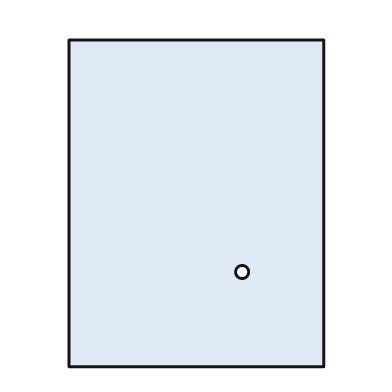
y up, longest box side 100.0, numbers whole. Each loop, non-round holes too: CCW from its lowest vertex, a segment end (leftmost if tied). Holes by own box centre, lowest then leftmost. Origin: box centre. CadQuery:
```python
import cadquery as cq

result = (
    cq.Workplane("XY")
    .moveTo(-39.0, -50.0)
    .lineTo(39.0, -50.0)
    .lineTo(39.0, 50.0)
    .lineTo(-39.0, 50.0)
    .close()
    .moveTo(14.0, -21.0)
    .circle(2.0)
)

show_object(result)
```